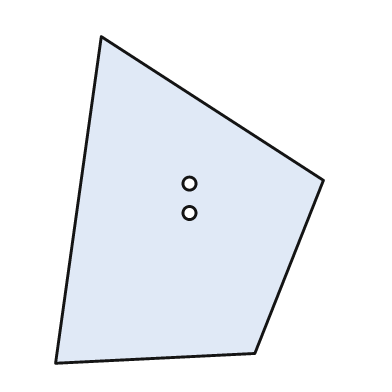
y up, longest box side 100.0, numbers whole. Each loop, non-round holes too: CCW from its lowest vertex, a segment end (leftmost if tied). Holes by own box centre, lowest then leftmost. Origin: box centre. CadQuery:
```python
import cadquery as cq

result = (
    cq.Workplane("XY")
    .moveTo(-41.0, -50.0)
    .lineTo(20.0, -47.0)
    .lineTo(41.0, 6.0)
    .lineTo(-27.0, 50.0)
    .close()
    .moveTo(0.0, -4.0)
    .circle(2.0)
    .moveTo(0.0, 5.0)
    .circle(2.0)
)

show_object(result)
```